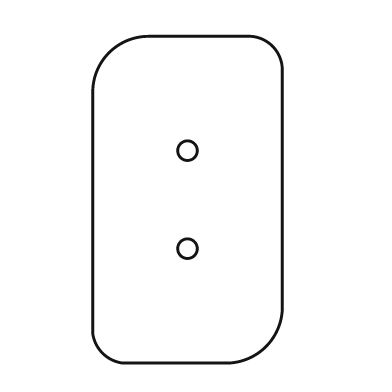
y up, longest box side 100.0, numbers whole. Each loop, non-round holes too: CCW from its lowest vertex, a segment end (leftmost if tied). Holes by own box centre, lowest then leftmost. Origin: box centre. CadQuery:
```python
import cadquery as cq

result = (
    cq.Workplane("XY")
    .moveTo(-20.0, -50.0)
    .lineTo(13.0, -50.0)
    .threePointArc((24.0, -45.0), (29.0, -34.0))
    .lineTo(29.0, 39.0)
    .threePointArc((26.0, 47.0), (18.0, 50.0))
    .lineTo(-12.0, 50.0)
    .threePointArc((-24.0, 45.0), (-29.0, 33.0))
    .lineTo(-29.0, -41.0)
    .threePointArc((-26.0, -47.0), (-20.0, -50.0))
    .close()
    .moveTo(0.0, -15.0)
    .circle(3.0)
    .moveTo(0.0, 15.0)
    .circle(3.0)
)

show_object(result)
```